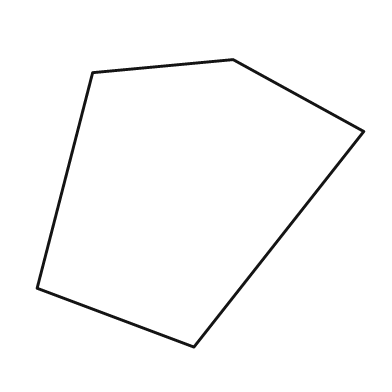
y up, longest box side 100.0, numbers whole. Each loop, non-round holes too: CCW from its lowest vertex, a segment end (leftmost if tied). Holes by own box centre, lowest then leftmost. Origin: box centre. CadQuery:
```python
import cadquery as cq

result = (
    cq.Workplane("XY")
    .moveTo(-2.0, -44.0)
    .lineTo(50.0, 22.0)
    .lineTo(10.0, 44.0)
    .lineTo(-33.0, 40.0)
    .lineTo(-50.0, -26.0)
    .close()
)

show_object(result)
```